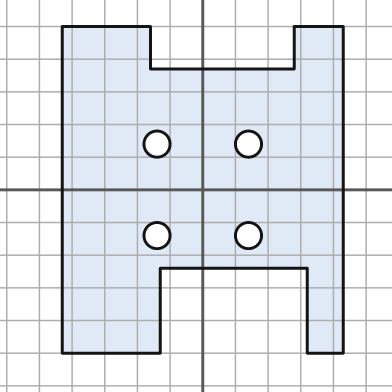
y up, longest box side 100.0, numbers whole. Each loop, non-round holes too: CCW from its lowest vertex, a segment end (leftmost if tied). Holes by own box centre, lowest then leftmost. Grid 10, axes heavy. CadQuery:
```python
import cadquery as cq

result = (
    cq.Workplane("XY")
    .moveTo(-43.0, -50.0)
    .lineTo(-13.0, -50.0)
    .lineTo(-13.0, -24.0)
    .lineTo(32.0, -24.0)
    .lineTo(32.0, -50.0)
    .lineTo(43.0, -50.0)
    .lineTo(43.0, 50.0)
    .lineTo(28.0, 50.0)
    .lineTo(28.0, 37.0)
    .lineTo(-16.0, 37.0)
    .lineTo(-16.0, 50.0)
    .lineTo(-43.0, 50.0)
    .close()
    .moveTo(-14.0, -14.0)
    .circle(4.0)
    .moveTo(14.0, -14.0)
    .circle(4.0)
    .moveTo(-14.0, 14.0)
    .circle(4.0)
    .moveTo(14.0, 14.0)
    .circle(4.0)
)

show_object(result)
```